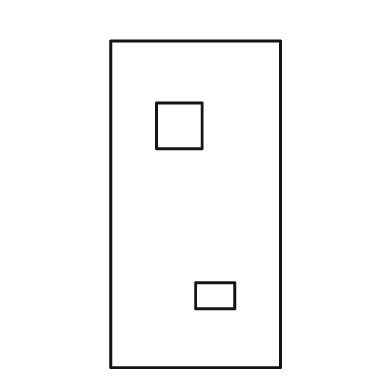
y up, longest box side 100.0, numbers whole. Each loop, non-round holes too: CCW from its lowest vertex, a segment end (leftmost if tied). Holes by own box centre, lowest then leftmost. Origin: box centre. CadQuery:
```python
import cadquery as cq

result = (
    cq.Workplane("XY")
    .moveTo(-26.0, -50.0)
    .lineTo(26.0, -50.0)
    .lineTo(26.0, 50.0)
    .lineTo(-26.0, 50.0)
    .close()
    .moveTo(0.0, -32.0)
    .lineTo(12.0, -32.0)
    .lineTo(12.0, -24.0)
    .lineTo(0.0, -24.0)
    .close()
    .moveTo(-12.0, 17.0)
    .lineTo(2.0, 17.0)
    .lineTo(2.0, 31.0)
    .lineTo(-12.0, 31.0)
    .close()
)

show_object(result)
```